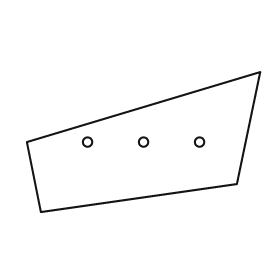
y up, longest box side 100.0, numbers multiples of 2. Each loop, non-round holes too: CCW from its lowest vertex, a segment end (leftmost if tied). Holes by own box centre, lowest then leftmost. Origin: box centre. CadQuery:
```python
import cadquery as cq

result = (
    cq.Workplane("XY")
    .moveTo(-44.0, -30.0)
    .lineTo(40.0, -18.0)
    .lineTo(50.0, 30.0)
    .lineTo(-50.0, 0.0)
    .close()
    .moveTo(-24.0, 0.0)
    .circle(2.0)
    .moveTo(0.0, 0.0)
    .circle(2.0)
    .moveTo(24.0, 0.0)
    .circle(2.0)
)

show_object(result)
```